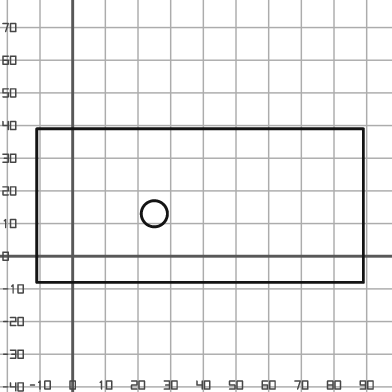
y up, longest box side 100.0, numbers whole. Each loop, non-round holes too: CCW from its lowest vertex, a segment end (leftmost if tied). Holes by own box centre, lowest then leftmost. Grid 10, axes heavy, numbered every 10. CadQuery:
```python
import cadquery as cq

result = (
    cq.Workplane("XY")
    .moveTo(-11.0, -8.0)
    .lineTo(89.0, -8.0)
    .lineTo(89.0, 39.0)
    .lineTo(-11.0, 39.0)
    .close()
    .moveTo(25.0, 13.0)
    .circle(4.0)
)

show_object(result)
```